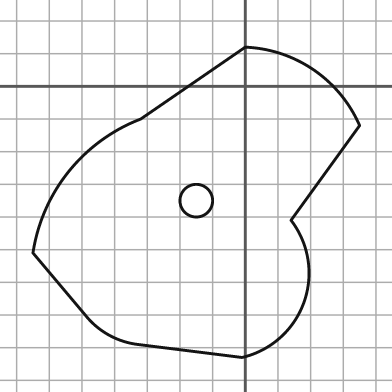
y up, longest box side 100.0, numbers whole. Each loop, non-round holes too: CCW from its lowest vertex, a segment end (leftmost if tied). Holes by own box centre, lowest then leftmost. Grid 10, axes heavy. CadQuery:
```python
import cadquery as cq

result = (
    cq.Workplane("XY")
    .moveTo(-1.0, -83.0)
    .threePointArc((18.0, -66.0), (14.0, -41.0))
    .lineTo(35.0, -12.0)
    .threePointArc((21.0, 5.0), (0.0, 12.0))
    .lineTo(-32.0, -10.0)
    .threePointArc((-54.0, -26.0), (-65.0, -51.0))
    .lineTo(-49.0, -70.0)
    .threePointArc((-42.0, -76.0), (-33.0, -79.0))
    .close()
    .moveTo(-15.0, -35.0)
    .circle(5.0)
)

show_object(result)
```